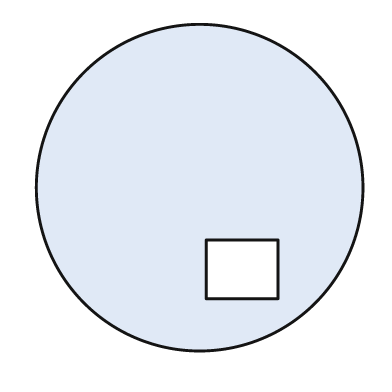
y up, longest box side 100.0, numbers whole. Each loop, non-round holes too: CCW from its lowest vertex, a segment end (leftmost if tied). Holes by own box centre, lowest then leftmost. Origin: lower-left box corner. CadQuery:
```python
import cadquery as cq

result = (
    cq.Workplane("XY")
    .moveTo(50.0, 50.0)
    .circle(50.0)
    .moveTo(52.0, 16.0)
    .lineTo(74.0, 16.0)
    .lineTo(74.0, 34.0)
    .lineTo(52.0, 34.0)
    .close()
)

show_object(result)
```